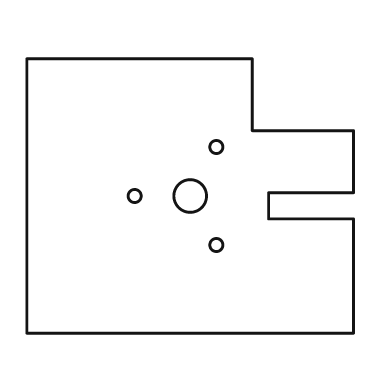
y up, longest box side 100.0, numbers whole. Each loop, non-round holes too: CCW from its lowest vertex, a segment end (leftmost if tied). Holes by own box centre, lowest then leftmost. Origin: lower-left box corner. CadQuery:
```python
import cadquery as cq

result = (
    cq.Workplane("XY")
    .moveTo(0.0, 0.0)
    .lineTo(100.0, 0.0)
    .lineTo(100.0, 35.0)
    .lineTo(74.0, 35.0)
    .lineTo(74.0, 43.0)
    .lineTo(100.0, 43.0)
    .lineTo(100.0, 62.0)
    .lineTo(69.0, 62.0)
    .lineTo(69.0, 84.0)
    .lineTo(0.0, 84.0)
    .close()
    .moveTo(58.0, 27.0)
    .circle(2.0)
    .moveTo(33.0, 42.0)
    .circle(2.0)
    .moveTo(50.0, 42.0)
    .circle(5.0)
    .moveTo(58.0, 57.0)
    .circle(2.0)
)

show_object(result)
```